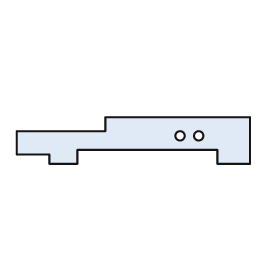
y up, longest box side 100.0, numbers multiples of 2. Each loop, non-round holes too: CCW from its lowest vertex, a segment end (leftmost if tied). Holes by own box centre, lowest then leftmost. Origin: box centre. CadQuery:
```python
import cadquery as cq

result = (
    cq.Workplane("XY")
    .moveTo(-36.0, -10.0)
    .lineTo(-24.0, -10.0)
    .lineTo(-24.0, -4.0)
    .lineTo(36.0, -4.0)
    .lineTo(36.0, -10.0)
    .lineTo(50.0, -10.0)
    .lineTo(50.0, 10.0)
    .lineTo(-12.0, 10.0)
    .lineTo(-12.0, 4.0)
    .lineTo(-50.0, 4.0)
    .lineTo(-50.0, -6.0)
    .lineTo(-36.0, -6.0)
    .close()
    .moveTo(20.0, 2.0)
    .circle(2.0)
    .moveTo(28.0, 2.0)
    .circle(2.0)
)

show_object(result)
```